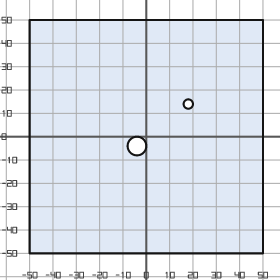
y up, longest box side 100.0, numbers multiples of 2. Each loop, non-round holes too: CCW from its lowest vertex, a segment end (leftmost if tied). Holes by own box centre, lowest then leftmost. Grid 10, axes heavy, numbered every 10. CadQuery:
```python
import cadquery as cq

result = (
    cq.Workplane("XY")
    .moveTo(-50.0, -50.0)
    .lineTo(50.0, -50.0)
    .lineTo(50.0, 50.0)
    .lineTo(-50.0, 50.0)
    .close()
    .moveTo(-4.0, -4.0)
    .circle(4.0)
    .moveTo(18.0, 14.0)
    .circle(2.0)
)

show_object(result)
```